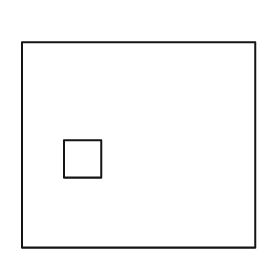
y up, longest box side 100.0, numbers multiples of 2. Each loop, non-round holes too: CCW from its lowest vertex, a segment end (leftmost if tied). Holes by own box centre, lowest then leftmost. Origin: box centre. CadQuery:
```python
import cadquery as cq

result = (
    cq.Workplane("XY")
    .moveTo(-50.0, -44.0)
    .lineTo(50.0, -44.0)
    .lineTo(50.0, 44.0)
    .lineTo(-50.0, 44.0)
    .close()
    .moveTo(-32.0, -14.0)
    .lineTo(-16.0, -14.0)
    .lineTo(-16.0, 2.0)
    .lineTo(-32.0, 2.0)
    .close()
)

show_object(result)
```